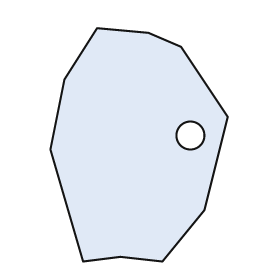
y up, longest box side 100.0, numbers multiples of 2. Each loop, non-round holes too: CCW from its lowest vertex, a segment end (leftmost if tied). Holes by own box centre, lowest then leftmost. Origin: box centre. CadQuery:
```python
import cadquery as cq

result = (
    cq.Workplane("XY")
    .moveTo(-24.0, -50.0)
    .lineTo(-8.0, -48.0)
    .lineTo(10.0, -50.0)
    .lineTo(28.0, -28.0)
    .lineTo(38.0, 12.0)
    .lineTo(18.0, 42.0)
    .lineTo(4.0, 48.0)
    .lineTo(-18.0, 50.0)
    .lineTo(-32.0, 28.0)
    .lineTo(-38.0, -2.0)
    .close()
    .moveTo(22.0, 4.0)
    .circle(6.0)
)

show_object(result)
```